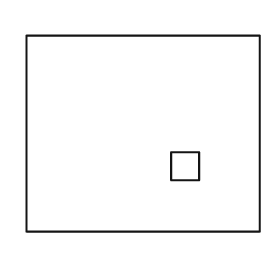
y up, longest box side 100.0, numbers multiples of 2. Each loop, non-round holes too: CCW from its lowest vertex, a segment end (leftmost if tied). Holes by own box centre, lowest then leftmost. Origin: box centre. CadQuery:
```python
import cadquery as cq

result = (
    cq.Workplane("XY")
    .moveTo(-50.0, -42.0)
    .lineTo(50.0, -42.0)
    .lineTo(50.0, 42.0)
    .lineTo(-50.0, 42.0)
    .close()
    .moveTo(12.0, -20.0)
    .lineTo(24.0, -20.0)
    .lineTo(24.0, -8.0)
    .lineTo(12.0, -8.0)
    .close()
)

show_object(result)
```